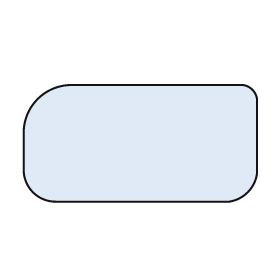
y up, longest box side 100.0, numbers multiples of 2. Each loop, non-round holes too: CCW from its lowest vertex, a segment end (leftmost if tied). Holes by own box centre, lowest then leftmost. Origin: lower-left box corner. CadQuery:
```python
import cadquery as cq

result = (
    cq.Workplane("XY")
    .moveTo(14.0, 0.0)
    .lineTo(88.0, 0.0)
    .threePointArc((96.0, 4.0), (100.0, 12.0))
    .lineTo(100.0, 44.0)
    .threePointArc((98.0, 48.0), (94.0, 50.0))
    .lineTo(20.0, 50.0)
    .threePointArc((6.0, 44.0), (0.0, 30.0))
    .lineTo(0.0, 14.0)
    .threePointArc((4.0, 4.0), (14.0, 0.0))
    .close()
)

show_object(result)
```